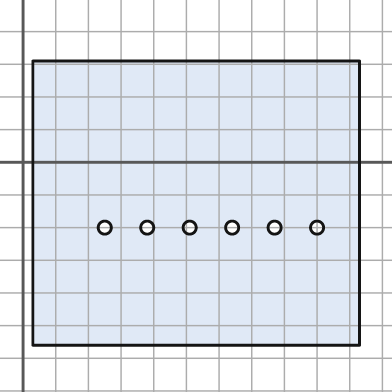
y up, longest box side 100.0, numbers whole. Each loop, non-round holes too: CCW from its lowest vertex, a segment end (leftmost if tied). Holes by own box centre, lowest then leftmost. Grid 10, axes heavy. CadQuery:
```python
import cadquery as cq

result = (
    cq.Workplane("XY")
    .moveTo(3.0, -56.0)
    .lineTo(103.0, -56.0)
    .lineTo(103.0, 31.0)
    .lineTo(3.0, 31.0)
    .close()
    .moveTo(25.0, -20.0)
    .circle(2.0)
    .moveTo(38.0, -20.0)
    .circle(2.0)
    .moveTo(51.0, -20.0)
    .circle(2.0)
    .moveTo(64.0, -20.0)
    .circle(2.0)
    .moveTo(77.0, -20.0)
    .circle(2.0)
    .moveTo(90.0, -20.0)
    .circle(2.0)
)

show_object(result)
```